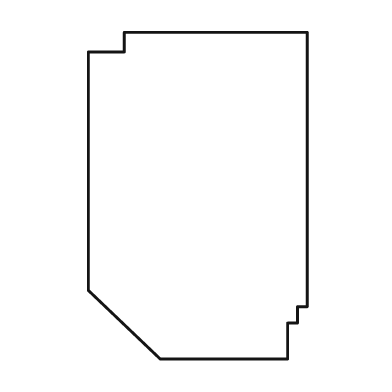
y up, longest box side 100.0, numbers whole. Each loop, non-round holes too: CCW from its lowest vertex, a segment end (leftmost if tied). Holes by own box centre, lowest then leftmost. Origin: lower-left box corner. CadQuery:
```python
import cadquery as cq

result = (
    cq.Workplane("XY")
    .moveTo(22.0, 0.0)
    .lineTo(61.0, 0.0)
    .lineTo(61.0, 11.0)
    .lineTo(64.0, 11.0)
    .lineTo(64.0, 16.0)
    .lineTo(67.0, 16.0)
    .lineTo(67.0, 100.0)
    .lineTo(11.0, 100.0)
    .lineTo(11.0, 94.0)
    .lineTo(0.0, 94.0)
    .lineTo(0.0, 21.0)
    .close()
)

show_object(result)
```